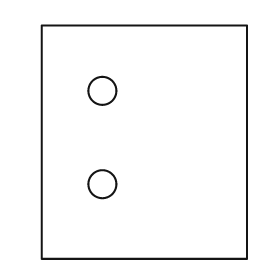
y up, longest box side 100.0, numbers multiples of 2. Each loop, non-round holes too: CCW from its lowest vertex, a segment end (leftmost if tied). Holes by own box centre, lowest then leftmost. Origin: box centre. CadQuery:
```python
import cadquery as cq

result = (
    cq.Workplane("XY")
    .moveTo(-44.0, -50.0)
    .lineTo(44.0, -50.0)
    .lineTo(44.0, 50.0)
    .lineTo(-44.0, 50.0)
    .close()
    .moveTo(-18.0, -18.0)
    .circle(6.0)
    .moveTo(-18.0, 22.0)
    .circle(6.0)
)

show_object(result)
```